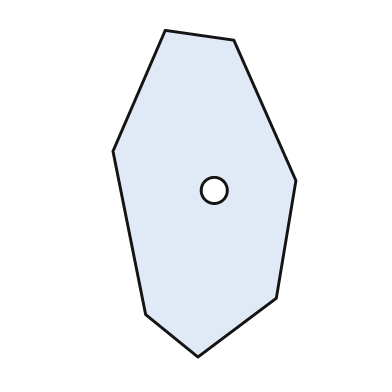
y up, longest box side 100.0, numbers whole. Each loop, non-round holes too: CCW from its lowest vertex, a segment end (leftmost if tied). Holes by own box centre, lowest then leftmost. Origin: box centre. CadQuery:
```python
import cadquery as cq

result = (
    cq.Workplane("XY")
    .moveTo(-2.0, -50.0)
    .lineTo(22.0, -32.0)
    .lineTo(28.0, 4.0)
    .lineTo(9.0, 47.0)
    .lineTo(-12.0, 50.0)
    .lineTo(-28.0, 13.0)
    .lineTo(-18.0, -37.0)
    .close()
    .moveTo(3.0, 1.0)
    .circle(4.0)
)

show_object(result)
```